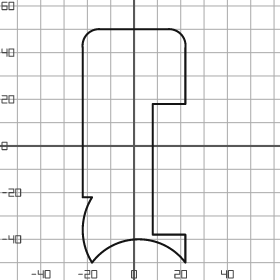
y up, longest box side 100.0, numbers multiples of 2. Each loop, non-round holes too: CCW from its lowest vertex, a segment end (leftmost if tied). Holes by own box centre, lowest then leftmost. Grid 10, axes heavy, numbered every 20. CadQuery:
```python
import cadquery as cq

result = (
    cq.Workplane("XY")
    .moveTo(-18.0, -50.0)
    .threePointArc((2.0, -40.0), (22.0, -50.0))
    .lineTo(22.0, -38.0)
    .lineTo(8.0, -38.0)
    .lineTo(8.0, 18.0)
    .lineTo(22.0, 18.0)
    .lineTo(22.0, 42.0)
    .threePointArc((20.0, 48.0), (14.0, 50.0))
    .lineTo(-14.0, 50.0)
    .threePointArc((-20.0, 48.0), (-22.0, 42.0))
    .lineTo(-22.0, -22.0)
    .lineTo(-18.0, -22.0)
    .threePointArc((-22.0, -36.0), (-18.0, -50.0))
    .close()
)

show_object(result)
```